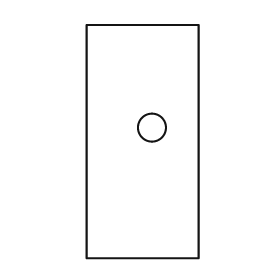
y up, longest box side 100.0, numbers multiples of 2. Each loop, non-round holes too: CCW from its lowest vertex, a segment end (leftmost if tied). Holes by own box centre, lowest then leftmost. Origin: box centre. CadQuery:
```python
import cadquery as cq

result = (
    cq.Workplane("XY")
    .moveTo(-24.0, -50.0)
    .lineTo(24.0, -50.0)
    .lineTo(24.0, 50.0)
    .lineTo(-24.0, 50.0)
    .close()
    .moveTo(4.0, 6.0)
    .circle(6.0)
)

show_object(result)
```